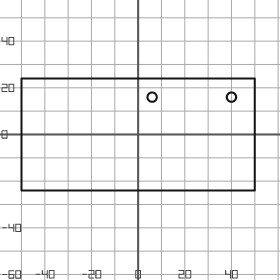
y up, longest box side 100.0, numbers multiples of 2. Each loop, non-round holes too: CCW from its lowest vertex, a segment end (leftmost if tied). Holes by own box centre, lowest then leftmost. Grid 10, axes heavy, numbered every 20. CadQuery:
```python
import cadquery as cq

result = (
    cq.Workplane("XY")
    .moveTo(-50.0, -24.0)
    .lineTo(50.0, -24.0)
    .lineTo(50.0, 24.0)
    .lineTo(-50.0, 24.0)
    .close()
    .moveTo(6.0, 16.0)
    .circle(2.0)
    .moveTo(40.0, 16.0)
    .circle(2.0)
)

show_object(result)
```